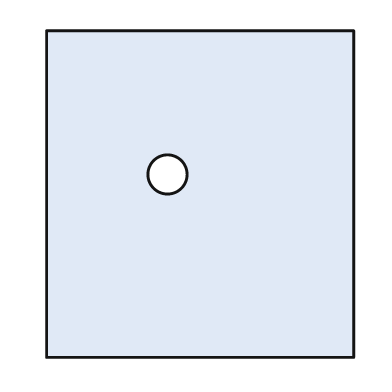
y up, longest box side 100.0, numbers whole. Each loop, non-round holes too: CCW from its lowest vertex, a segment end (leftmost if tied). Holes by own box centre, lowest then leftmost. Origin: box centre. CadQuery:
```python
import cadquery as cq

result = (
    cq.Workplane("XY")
    .moveTo(-47.0, -50.0)
    .lineTo(47.0, -50.0)
    .lineTo(47.0, 50.0)
    .lineTo(-47.0, 50.0)
    .close()
    .moveTo(-10.0, 6.0)
    .circle(6.0)
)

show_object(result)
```